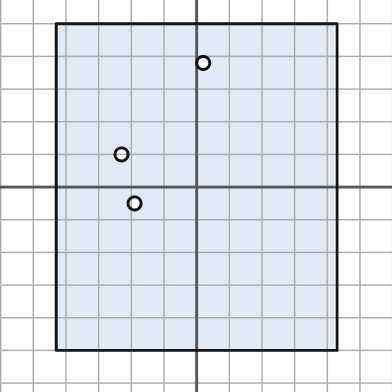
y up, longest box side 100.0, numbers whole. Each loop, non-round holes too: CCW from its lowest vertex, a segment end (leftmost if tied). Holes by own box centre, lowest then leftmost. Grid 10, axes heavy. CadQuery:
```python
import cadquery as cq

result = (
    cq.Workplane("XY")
    .moveTo(-43.0, -50.0)
    .lineTo(43.0, -50.0)
    .lineTo(43.0, 50.0)
    .lineTo(-43.0, 50.0)
    .close()
    .moveTo(-19.0, -5.0)
    .circle(2.0)
    .moveTo(-23.0, 10.0)
    .circle(2.0)
    .moveTo(2.0, 38.0)
    .circle(2.0)
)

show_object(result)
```